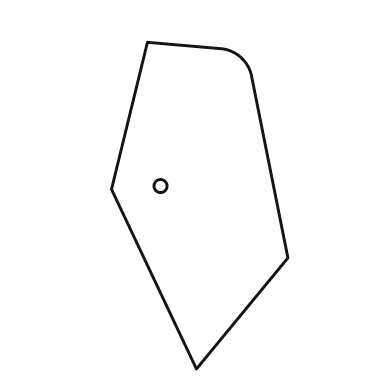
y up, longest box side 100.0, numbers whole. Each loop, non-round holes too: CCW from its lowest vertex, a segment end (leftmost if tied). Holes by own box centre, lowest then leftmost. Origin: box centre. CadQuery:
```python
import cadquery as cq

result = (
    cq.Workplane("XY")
    .moveTo(-1.0, -50.0)
    .lineTo(27.0, -16.0)
    .lineTo(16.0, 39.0)
    .threePointArc((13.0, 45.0), (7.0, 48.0))
    .lineTo(-16.0, 50.0)
    .lineTo(-27.0, 5.0)
    .close()
    .moveTo(-12.0, 6.0)
    .circle(2.0)
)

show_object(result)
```